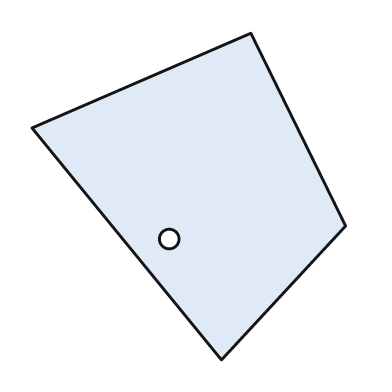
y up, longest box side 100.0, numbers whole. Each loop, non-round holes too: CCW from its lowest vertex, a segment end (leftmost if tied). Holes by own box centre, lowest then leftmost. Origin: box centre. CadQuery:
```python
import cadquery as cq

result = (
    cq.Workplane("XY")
    .moveTo(10.0, -50.0)
    .lineTo(48.0, -9.0)
    .lineTo(19.0, 50.0)
    .lineTo(-48.0, 21.0)
    .close()
    .moveTo(-6.0, -13.0)
    .circle(3.0)
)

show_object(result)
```